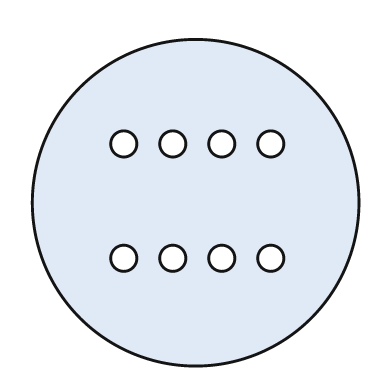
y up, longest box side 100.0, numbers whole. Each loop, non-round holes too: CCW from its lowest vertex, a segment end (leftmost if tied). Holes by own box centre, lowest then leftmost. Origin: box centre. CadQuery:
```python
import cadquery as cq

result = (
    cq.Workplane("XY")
    .moveTo(0.0, 0.0)
    .circle(50.0)
    .moveTo(-22.0, -17.0)
    .circle(4.0)
    .moveTo(-7.0, -17.0)
    .circle(4.0)
    .moveTo(8.0, -17.0)
    .circle(4.0)
    .moveTo(23.0, -17.0)
    .circle(4.0)
    .moveTo(-22.0, 18.0)
    .circle(4.0)
    .moveTo(-7.0, 18.0)
    .circle(4.0)
    .moveTo(8.0, 18.0)
    .circle(4.0)
    .moveTo(23.0, 18.0)
    .circle(4.0)
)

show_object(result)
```